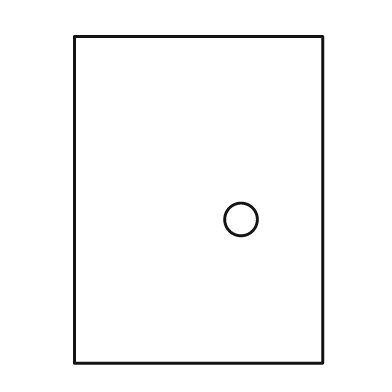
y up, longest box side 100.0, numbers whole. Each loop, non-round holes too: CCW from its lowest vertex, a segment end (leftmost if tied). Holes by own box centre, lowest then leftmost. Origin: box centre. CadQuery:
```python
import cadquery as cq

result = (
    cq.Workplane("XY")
    .moveTo(-38.0, -50.0)
    .lineTo(38.0, -50.0)
    .lineTo(38.0, 50.0)
    .lineTo(-38.0, 50.0)
    .close()
    .moveTo(13.0, -6.0)
    .circle(5.0)
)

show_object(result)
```